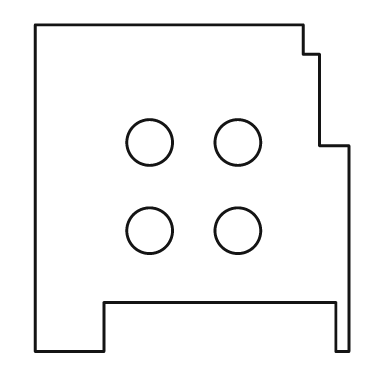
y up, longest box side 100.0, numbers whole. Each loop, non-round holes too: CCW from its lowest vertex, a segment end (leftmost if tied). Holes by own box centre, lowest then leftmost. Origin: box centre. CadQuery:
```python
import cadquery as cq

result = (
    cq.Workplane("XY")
    .moveTo(-48.0, -50.0)
    .lineTo(-27.0, -50.0)
    .lineTo(-27.0, -35.0)
    .lineTo(44.0, -35.0)
    .lineTo(44.0, -50.0)
    .lineTo(48.0, -50.0)
    .lineTo(48.0, 13.0)
    .lineTo(39.0, 13.0)
    .lineTo(39.0, 41.0)
    .lineTo(34.0, 41.0)
    .lineTo(34.0, 50.0)
    .lineTo(-48.0, 50.0)
    .close()
    .moveTo(-13.0, -13.0)
    .circle(7.0)
    .moveTo(14.0, -13.0)
    .circle(7.0)
    .moveTo(-13.0, 14.0)
    .circle(7.0)
    .moveTo(14.0, 14.0)
    .circle(7.0)
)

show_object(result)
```